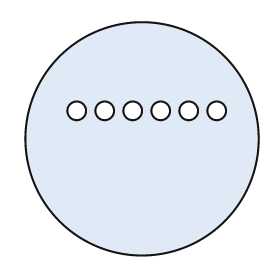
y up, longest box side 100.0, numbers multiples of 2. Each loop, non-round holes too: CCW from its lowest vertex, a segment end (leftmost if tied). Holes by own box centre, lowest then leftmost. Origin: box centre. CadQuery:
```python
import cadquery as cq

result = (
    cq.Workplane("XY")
    .moveTo(0.0, 0.0)
    .circle(50.0)
    .moveTo(-28.0, 12.0)
    .circle(4.0)
    .moveTo(-16.0, 12.0)
    .circle(4.0)
    .moveTo(-4.0, 12.0)
    .circle(4.0)
    .moveTo(8.0, 12.0)
    .circle(4.0)
    .moveTo(20.0, 12.0)
    .circle(4.0)
    .moveTo(32.0, 12.0)
    .circle(4.0)
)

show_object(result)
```